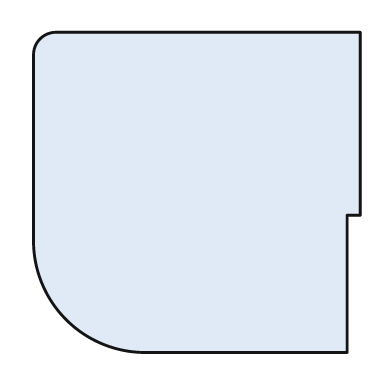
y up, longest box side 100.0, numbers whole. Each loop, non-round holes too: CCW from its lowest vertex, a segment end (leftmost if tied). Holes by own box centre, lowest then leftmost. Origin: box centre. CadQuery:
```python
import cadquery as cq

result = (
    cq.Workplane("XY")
    .moveTo(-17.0, -49.0)
    .lineTo(46.0, -49.0)
    .lineTo(46.0, -7.0)
    .lineTo(50.0, -7.0)
    .lineTo(50.0, 49.0)
    .lineTo(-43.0, 49.0)
    .threePointArc((-48.0, 47.0), (-50.0, 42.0))
    .lineTo(-50.0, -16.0)
    .threePointArc((-40.0, -39.0), (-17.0, -49.0))
    .close()
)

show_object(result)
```